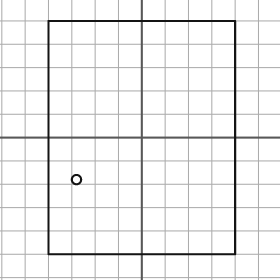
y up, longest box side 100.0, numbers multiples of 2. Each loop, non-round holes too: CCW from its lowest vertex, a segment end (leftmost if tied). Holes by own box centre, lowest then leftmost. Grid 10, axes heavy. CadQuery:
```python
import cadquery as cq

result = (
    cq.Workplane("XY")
    .moveTo(-40.0, -50.0)
    .lineTo(40.0, -50.0)
    .lineTo(40.0, 50.0)
    .lineTo(-40.0, 50.0)
    .close()
    .moveTo(-28.0, -18.0)
    .circle(2.0)
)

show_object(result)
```